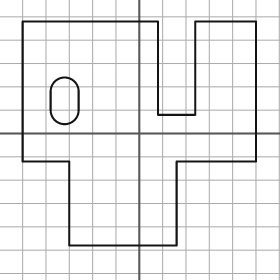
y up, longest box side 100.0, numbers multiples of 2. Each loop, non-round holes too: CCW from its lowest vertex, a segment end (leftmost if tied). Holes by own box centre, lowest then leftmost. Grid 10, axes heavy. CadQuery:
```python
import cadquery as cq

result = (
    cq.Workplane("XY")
    .moveTo(-30.0, -48.0)
    .lineTo(16.0, -48.0)
    .lineTo(16.0, -12.0)
    .lineTo(50.0, -12.0)
    .lineTo(50.0, 48.0)
    .lineTo(24.0, 48.0)
    .lineTo(24.0, 8.0)
    .lineTo(8.0, 8.0)
    .lineTo(8.0, 48.0)
    .lineTo(-50.0, 48.0)
    .lineTo(-50.0, -12.0)
    .lineTo(-30.0, -12.0)
    .close()
    .moveTo(-38.0, 10.0)
    .threePointArc((-32.0, 4.0), (-26.0, 10.0))
    .lineTo(-26.0, 18.0)
    .threePointArc((-32.0, 24.0), (-38.0, 18.0))
    .close()
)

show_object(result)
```